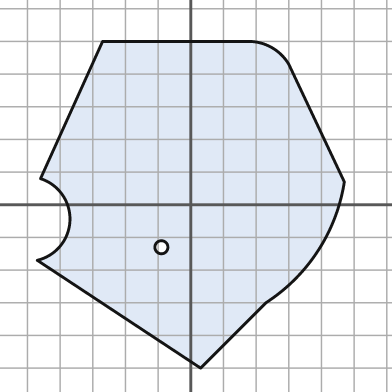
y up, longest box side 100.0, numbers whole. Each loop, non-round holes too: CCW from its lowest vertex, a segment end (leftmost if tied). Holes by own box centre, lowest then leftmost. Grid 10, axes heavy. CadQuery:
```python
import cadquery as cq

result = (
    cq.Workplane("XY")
    .moveTo(3.0, -50.0)
    .lineTo(23.0, -30.0)
    .threePointArc((39.0, -14.0), (47.0, 7.0))
    .lineTo(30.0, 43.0)
    .threePointArc((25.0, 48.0), (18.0, 50.0))
    .lineTo(-27.0, 50.0)
    .lineTo(-46.0, 8.0)
    .threePointArc((-37.0, -5.0), (-47.0, -17.0))
    .close()
    .moveTo(-9.0, -13.0)
    .circle(2.0)
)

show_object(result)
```